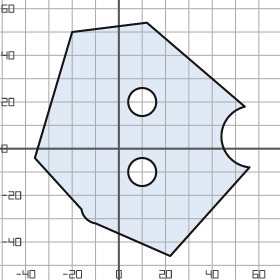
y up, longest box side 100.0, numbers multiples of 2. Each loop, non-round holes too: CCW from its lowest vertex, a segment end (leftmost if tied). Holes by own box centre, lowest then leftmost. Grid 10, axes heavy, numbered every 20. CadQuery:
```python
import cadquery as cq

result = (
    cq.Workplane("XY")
    .moveTo(22.0, -46.0)
    .lineTo(56.0, -8.0)
    .threePointArc((44.0, 4.0), (54.0, 18.0))
    .lineTo(12.0, 54.0)
    .lineTo(-20.0, 50.0)
    .lineTo(-36.0, -4.0)
    .lineTo(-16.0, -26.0)
    .threePointArc((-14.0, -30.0), (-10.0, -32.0))
    .close()
    .moveTo(10.0, -10.0)
    .circle(6.0)
    .moveTo(10.0, 20.0)
    .circle(6.0)
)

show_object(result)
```